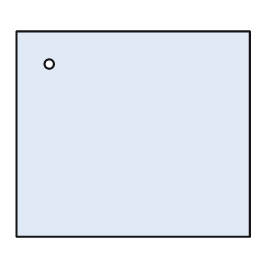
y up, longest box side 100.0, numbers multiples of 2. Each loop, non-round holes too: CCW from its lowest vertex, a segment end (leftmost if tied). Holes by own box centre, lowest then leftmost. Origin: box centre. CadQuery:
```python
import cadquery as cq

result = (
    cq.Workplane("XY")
    .moveTo(-50.0, -44.0)
    .lineTo(50.0, -44.0)
    .lineTo(50.0, 44.0)
    .lineTo(-50.0, 44.0)
    .close()
    .moveTo(-36.0, 30.0)
    .circle(2.0)
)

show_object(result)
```